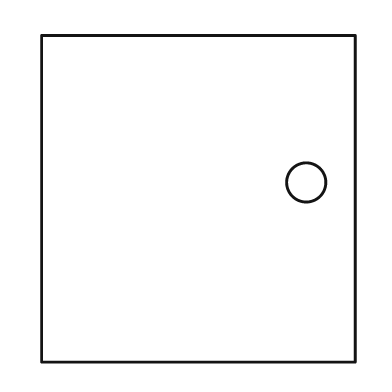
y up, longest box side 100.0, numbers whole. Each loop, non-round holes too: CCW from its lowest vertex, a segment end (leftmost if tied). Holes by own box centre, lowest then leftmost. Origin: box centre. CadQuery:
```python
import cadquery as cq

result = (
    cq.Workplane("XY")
    .moveTo(-48.0, -50.0)
    .lineTo(48.0, -50.0)
    .lineTo(48.0, 50.0)
    .lineTo(-48.0, 50.0)
    .close()
    .moveTo(33.0, 5.0)
    .circle(6.0)
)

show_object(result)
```